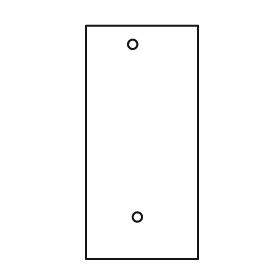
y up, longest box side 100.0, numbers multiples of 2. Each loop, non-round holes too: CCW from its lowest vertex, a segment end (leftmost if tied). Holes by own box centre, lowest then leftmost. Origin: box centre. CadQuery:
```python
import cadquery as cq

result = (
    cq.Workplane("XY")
    .moveTo(-24.0, -50.0)
    .lineTo(24.0, -50.0)
    .lineTo(24.0, 50.0)
    .lineTo(-24.0, 50.0)
    .close()
    .moveTo(-2.0, -32.0)
    .circle(2.0)
    .moveTo(-4.0, 42.0)
    .circle(2.0)
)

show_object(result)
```